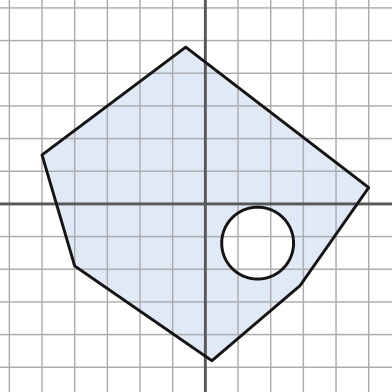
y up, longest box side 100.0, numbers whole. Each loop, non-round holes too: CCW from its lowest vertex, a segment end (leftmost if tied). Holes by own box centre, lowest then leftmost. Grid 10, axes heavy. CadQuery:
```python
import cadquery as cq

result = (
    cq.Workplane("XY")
    .moveTo(2.0, -48.0)
    .lineTo(29.0, -25.0)
    .lineTo(50.0, 5.0)
    .lineTo(-6.0, 48.0)
    .lineTo(-50.0, 15.0)
    .lineTo(-40.0, -19.0)
    .close()
    .moveTo(16.0, -12.0)
    .circle(11.0)
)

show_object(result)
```